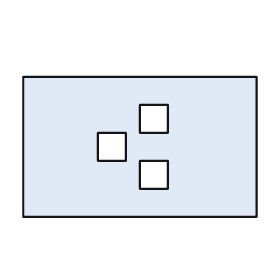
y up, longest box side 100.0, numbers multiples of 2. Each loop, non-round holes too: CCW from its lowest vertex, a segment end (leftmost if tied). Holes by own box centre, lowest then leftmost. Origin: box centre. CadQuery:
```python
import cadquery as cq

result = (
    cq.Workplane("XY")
    .moveTo(-50.0, -30.0)
    .lineTo(50.0, -30.0)
    .lineTo(50.0, 30.0)
    .lineTo(-50.0, 30.0)
    .close()
    .moveTo(0.0, -18.0)
    .lineTo(12.0, -18.0)
    .lineTo(12.0, -6.0)
    .lineTo(0.0, -6.0)
    .close()
    .moveTo(-18.0, -6.0)
    .lineTo(-6.0, -6.0)
    .lineTo(-6.0, 6.0)
    .lineTo(-18.0, 6.0)
    .close()
    .moveTo(0.0, 6.0)
    .lineTo(12.0, 6.0)
    .lineTo(12.0, 18.0)
    .lineTo(0.0, 18.0)
    .close()
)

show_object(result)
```